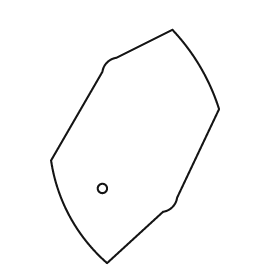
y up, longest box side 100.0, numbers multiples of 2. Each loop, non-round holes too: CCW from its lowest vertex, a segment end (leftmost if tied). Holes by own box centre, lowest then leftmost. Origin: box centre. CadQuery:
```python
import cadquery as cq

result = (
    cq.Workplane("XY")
    .moveTo(-12.0, -50.0)
    .lineTo(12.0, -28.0)
    .threePointArc((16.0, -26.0), (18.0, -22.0))
    .lineTo(36.0, 16.0)
    .threePointArc((28.0, 34.0), (16.0, 50.0))
    .lineTo(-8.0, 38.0)
    .threePointArc((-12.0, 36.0), (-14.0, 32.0))
    .lineTo(-36.0, -6.0)
    .threePointArc((-28.0, -30.0), (-12.0, -50.0))
    .close()
    .moveTo(-14.0, -18.0)
    .circle(2.0)
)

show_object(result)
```